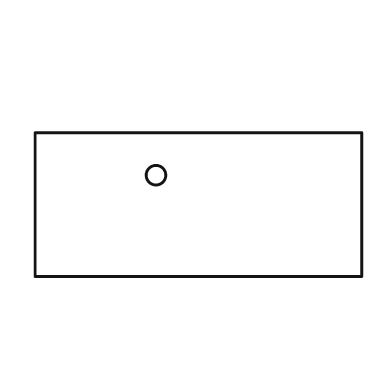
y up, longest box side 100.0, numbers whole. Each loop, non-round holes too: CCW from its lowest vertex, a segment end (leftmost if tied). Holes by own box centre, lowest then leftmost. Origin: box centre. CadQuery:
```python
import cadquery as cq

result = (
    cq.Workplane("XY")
    .moveTo(-50.0, -22.0)
    .lineTo(50.0, -22.0)
    .lineTo(50.0, 22.0)
    .lineTo(-50.0, 22.0)
    .close()
    .moveTo(-13.0, 9.0)
    .circle(3.0)
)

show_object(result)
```